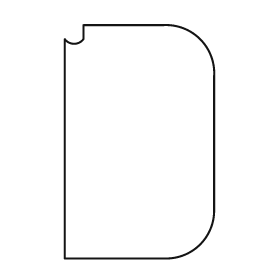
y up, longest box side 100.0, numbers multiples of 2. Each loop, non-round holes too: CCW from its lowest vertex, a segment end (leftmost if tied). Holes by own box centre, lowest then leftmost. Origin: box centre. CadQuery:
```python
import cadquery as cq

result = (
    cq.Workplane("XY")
    .moveTo(-32.0, -50.0)
    .lineTo(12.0, -50.0)
    .threePointArc((26.0, -44.0), (32.0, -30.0))
    .lineTo(32.0, 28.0)
    .threePointArc((26.0, 44.0), (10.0, 50.0))
    .lineTo(-24.0, 50.0)
    .lineTo(-24.0, 44.0)
    .threePointArc((-28.0, 42.0), (-32.0, 44.0))
    .close()
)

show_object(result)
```